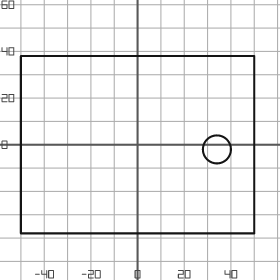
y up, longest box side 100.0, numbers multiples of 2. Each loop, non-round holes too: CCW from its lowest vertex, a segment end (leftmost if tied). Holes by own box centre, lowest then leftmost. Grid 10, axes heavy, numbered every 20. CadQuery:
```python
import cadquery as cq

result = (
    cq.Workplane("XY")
    .moveTo(-50.0, -38.0)
    .lineTo(50.0, -38.0)
    .lineTo(50.0, 38.0)
    .lineTo(-50.0, 38.0)
    .close()
    .moveTo(34.0, -2.0)
    .circle(6.0)
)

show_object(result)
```